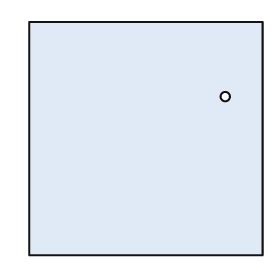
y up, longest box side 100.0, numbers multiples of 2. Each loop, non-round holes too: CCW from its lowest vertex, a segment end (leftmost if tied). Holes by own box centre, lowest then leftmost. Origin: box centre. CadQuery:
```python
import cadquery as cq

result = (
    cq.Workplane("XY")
    .moveTo(-50.0, -50.0)
    .lineTo(50.0, -50.0)
    .lineTo(50.0, 50.0)
    .lineTo(-50.0, 50.0)
    .close()
    .moveTo(34.0, 18.0)
    .circle(2.0)
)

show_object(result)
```